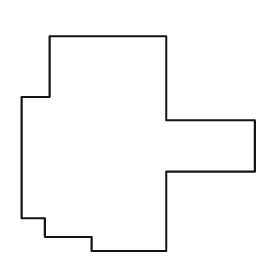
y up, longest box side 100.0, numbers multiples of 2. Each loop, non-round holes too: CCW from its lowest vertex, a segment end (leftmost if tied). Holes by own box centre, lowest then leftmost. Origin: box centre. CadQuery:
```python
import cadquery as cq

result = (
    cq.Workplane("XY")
    .moveTo(-20.0, -46.0)
    .lineTo(12.0, -46.0)
    .lineTo(12.0, -12.0)
    .lineTo(50.0, -12.0)
    .lineTo(50.0, 10.0)
    .lineTo(12.0, 10.0)
    .lineTo(12.0, 46.0)
    .lineTo(-38.0, 46.0)
    .lineTo(-38.0, 20.0)
    .lineTo(-50.0, 20.0)
    .lineTo(-50.0, -32.0)
    .lineTo(-40.0, -32.0)
    .lineTo(-40.0, -40.0)
    .lineTo(-20.0, -40.0)
    .close()
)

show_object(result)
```